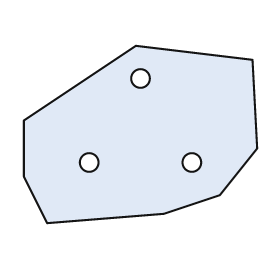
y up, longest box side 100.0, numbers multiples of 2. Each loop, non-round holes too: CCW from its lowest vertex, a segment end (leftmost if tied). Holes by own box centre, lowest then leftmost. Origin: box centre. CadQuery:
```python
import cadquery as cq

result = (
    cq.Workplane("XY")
    .moveTo(-40.0, -38.0)
    .lineTo(10.0, -34.0)
    .lineTo(34.0, -26.0)
    .lineTo(50.0, -6.0)
    .lineTo(48.0, 32.0)
    .lineTo(-2.0, 38.0)
    .lineTo(-50.0, 6.0)
    .lineTo(-50.0, -18.0)
    .close()
    .moveTo(-22.0, -12.0)
    .circle(4.0)
    .moveTo(22.0, -12.0)
    .circle(4.0)
    .moveTo(0.0, 24.0)
    .circle(4.0)
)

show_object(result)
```